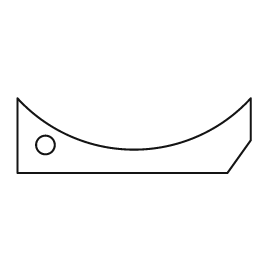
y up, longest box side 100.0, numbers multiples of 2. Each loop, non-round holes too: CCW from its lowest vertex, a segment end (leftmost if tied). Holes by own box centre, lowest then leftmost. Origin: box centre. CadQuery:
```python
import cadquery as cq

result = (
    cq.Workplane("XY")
    .moveTo(-50.0, -16.0)
    .lineTo(40.0, -16.0)
    .lineTo(50.0, -2.0)
    .lineTo(50.0, 16.0)
    .threePointArc((0.0, -6.0), (-50.0, 16.0))
    .close()
    .moveTo(-38.0, -4.0)
    .circle(4.0)
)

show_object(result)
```